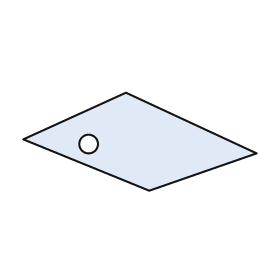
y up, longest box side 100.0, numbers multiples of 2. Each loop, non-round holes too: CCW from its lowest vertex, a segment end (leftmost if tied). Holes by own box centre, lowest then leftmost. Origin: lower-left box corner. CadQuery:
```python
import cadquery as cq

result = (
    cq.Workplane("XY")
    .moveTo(54.0, 0.0)
    .lineTo(100.0, 16.0)
    .lineTo(44.0, 42.0)
    .lineTo(0.0, 22.0)
    .close()
    .moveTo(28.0, 20.0)
    .circle(4.0)
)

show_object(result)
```